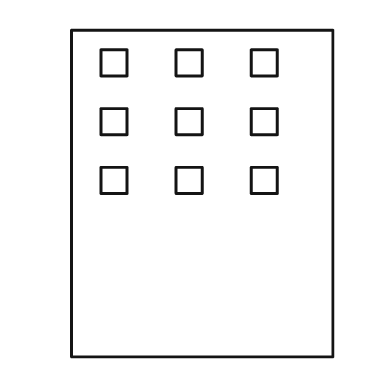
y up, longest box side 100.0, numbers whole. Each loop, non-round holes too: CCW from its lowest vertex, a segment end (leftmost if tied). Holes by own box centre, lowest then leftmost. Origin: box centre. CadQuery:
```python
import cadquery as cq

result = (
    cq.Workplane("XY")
    .moveTo(-40.0, -50.0)
    .lineTo(40.0, -50.0)
    .lineTo(40.0, 50.0)
    .lineTo(-40.0, 50.0)
    .close()
    .moveTo(-31.0, 0.0)
    .lineTo(-23.0, 0.0)
    .lineTo(-23.0, 8.0)
    .lineTo(-31.0, 8.0)
    .close()
    .moveTo(-8.0, 0.0)
    .lineTo(0.0, 0.0)
    .lineTo(0.0, 8.0)
    .lineTo(-8.0, 8.0)
    .close()
    .moveTo(15.0, 0.0)
    .lineTo(23.0, 0.0)
    .lineTo(23.0, 8.0)
    .lineTo(15.0, 8.0)
    .close()
    .moveTo(-31.0, 18.0)
    .lineTo(-23.0, 18.0)
    .lineTo(-23.0, 26.0)
    .lineTo(-31.0, 26.0)
    .close()
    .moveTo(-8.0, 18.0)
    .lineTo(0.0, 18.0)
    .lineTo(0.0, 26.0)
    .lineTo(-8.0, 26.0)
    .close()
    .moveTo(15.0, 18.0)
    .lineTo(23.0, 18.0)
    .lineTo(23.0, 26.0)
    .lineTo(15.0, 26.0)
    .close()
    .moveTo(-31.0, 36.0)
    .lineTo(-23.0, 36.0)
    .lineTo(-23.0, 44.0)
    .lineTo(-31.0, 44.0)
    .close()
    .moveTo(-8.0, 36.0)
    .lineTo(0.0, 36.0)
    .lineTo(0.0, 44.0)
    .lineTo(-8.0, 44.0)
    .close()
    .moveTo(15.0, 36.0)
    .lineTo(23.0, 36.0)
    .lineTo(23.0, 44.0)
    .lineTo(15.0, 44.0)
    .close()
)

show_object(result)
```